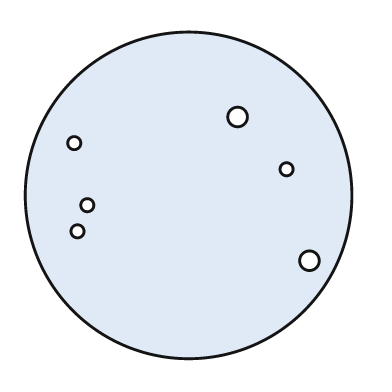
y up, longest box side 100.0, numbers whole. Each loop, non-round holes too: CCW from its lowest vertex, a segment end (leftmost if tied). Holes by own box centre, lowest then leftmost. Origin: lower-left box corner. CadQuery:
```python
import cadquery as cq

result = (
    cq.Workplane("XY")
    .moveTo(50.0, 50.0)
    .circle(50.0)
    .moveTo(87.0, 30.0)
    .circle(3.0)
    .moveTo(16.0, 39.0)
    .circle(2.0)
    .moveTo(19.0, 47.0)
    .circle(2.0)
    .moveTo(80.0, 58.0)
    .circle(2.0)
    .moveTo(15.0, 66.0)
    .circle(2.0)
    .moveTo(65.0, 74.0)
    .circle(3.0)
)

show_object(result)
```